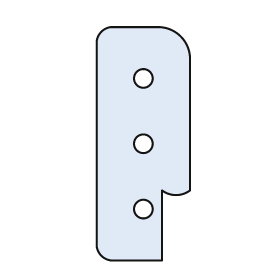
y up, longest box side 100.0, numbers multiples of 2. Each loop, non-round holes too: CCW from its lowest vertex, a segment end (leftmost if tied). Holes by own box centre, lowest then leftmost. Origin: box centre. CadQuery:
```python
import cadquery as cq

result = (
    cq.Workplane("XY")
    .moveTo(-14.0, -50.0)
    .lineTo(8.0, -50.0)
    .lineTo(8.0, -20.0)
    .threePointArc((14.0, -22.0), (20.0, -20.0))
    .lineTo(20.0, 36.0)
    .threePointArc((16.0, 46.0), (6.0, 50.0))
    .lineTo(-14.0, 50.0)
    .threePointArc((-18.0, 48.0), (-20.0, 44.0))
    .lineTo(-20.0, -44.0)
    .threePointArc((-18.0, -48.0), (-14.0, -50.0))
    .close()
    .moveTo(0.0, -28.0)
    .circle(4.0)
    .moveTo(0.0, 0.0)
    .circle(4.0)
    .moveTo(0.0, 28.0)
    .circle(4.0)
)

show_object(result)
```